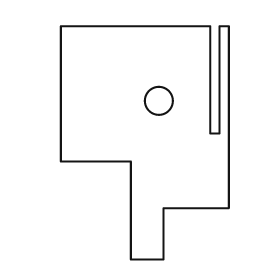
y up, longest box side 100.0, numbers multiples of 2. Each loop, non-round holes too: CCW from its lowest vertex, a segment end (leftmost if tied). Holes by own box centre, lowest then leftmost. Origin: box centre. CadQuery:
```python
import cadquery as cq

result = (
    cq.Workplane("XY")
    .moveTo(-6.0, -50.0)
    .lineTo(8.0, -50.0)
    .lineTo(8.0, -28.0)
    .lineTo(36.0, -28.0)
    .lineTo(36.0, 50.0)
    .lineTo(32.0, 50.0)
    .lineTo(32.0, 4.0)
    .lineTo(28.0, 4.0)
    .lineTo(28.0, 50.0)
    .lineTo(-36.0, 50.0)
    .lineTo(-36.0, -8.0)
    .lineTo(-6.0, -8.0)
    .close()
    .moveTo(6.0, 18.0)
    .circle(6.0)
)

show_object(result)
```